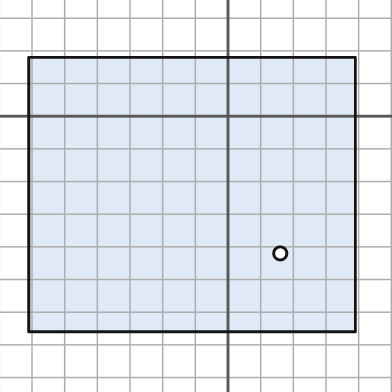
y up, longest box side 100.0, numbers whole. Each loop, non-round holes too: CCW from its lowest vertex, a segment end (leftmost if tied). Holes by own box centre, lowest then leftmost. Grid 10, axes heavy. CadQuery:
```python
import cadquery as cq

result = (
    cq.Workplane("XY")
    .moveTo(-61.0, -66.0)
    .lineTo(39.0, -66.0)
    .lineTo(39.0, 18.0)
    .lineTo(-61.0, 18.0)
    .close()
    .moveTo(16.0, -42.0)
    .circle(2.0)
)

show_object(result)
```